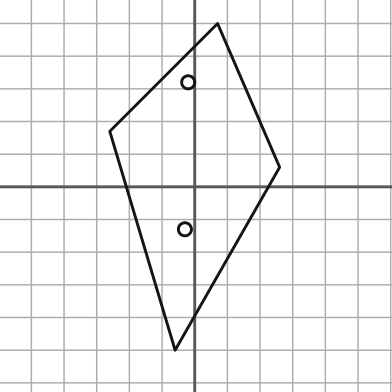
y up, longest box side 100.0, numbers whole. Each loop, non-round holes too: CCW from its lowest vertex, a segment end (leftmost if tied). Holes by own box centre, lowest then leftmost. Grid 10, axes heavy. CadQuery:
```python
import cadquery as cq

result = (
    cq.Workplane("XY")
    .moveTo(-6.0, -50.0)
    .lineTo(26.0, 6.0)
    .lineTo(7.0, 50.0)
    .lineTo(-26.0, 17.0)
    .close()
    .moveTo(-3.0, -13.0)
    .circle(2.0)
    .moveTo(-2.0, 32.0)
    .circle(2.0)
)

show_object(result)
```